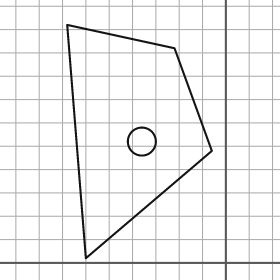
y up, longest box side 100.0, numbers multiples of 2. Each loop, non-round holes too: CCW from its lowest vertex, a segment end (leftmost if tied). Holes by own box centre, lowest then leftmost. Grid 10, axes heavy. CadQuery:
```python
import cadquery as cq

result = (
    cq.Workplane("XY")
    .moveTo(-60.0, 2.0)
    .lineTo(-6.0, 48.0)
    .lineTo(-22.0, 92.0)
    .lineTo(-68.0, 102.0)
    .close()
    .moveTo(-36.0, 52.0)
    .circle(6.0)
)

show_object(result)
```